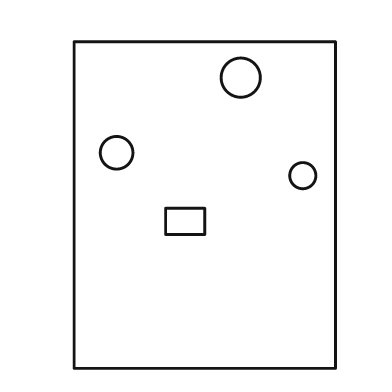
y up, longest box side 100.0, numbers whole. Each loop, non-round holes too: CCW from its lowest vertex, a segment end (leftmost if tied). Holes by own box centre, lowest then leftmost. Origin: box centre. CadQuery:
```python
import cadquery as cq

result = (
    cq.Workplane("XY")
    .moveTo(-40.0, -50.0)
    .lineTo(40.0, -50.0)
    .lineTo(40.0, 50.0)
    .lineTo(-40.0, 50.0)
    .close()
    .moveTo(-12.0, -9.0)
    .lineTo(0.0, -9.0)
    .lineTo(0.0, -1.0)
    .lineTo(-12.0, -1.0)
    .close()
    .moveTo(30.0, 9.0)
    .circle(4.0)
    .moveTo(-27.0, 16.0)
    .circle(5.0)
    .moveTo(11.0, 39.0)
    .circle(6.0)
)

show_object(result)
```